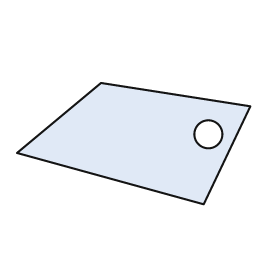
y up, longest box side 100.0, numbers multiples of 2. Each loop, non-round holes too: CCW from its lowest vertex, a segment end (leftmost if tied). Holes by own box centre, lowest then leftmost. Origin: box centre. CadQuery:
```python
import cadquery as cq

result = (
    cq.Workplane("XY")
    .moveTo(30.0, -26.0)
    .lineTo(50.0, 16.0)
    .lineTo(-14.0, 26.0)
    .lineTo(-50.0, -4.0)
    .close()
    .moveTo(32.0, 4.0)
    .circle(6.0)
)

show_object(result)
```